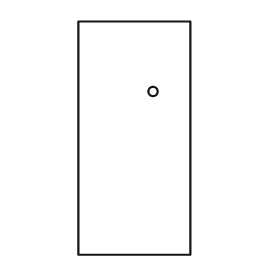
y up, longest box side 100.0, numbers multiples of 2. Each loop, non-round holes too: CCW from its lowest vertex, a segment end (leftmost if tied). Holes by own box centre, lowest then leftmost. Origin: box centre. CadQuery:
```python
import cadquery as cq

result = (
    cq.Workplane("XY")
    .moveTo(-24.0, -50.0)
    .lineTo(24.0, -50.0)
    .lineTo(24.0, 50.0)
    .lineTo(-24.0, 50.0)
    .close()
    .moveTo(8.0, 20.0)
    .circle(2.0)
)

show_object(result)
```